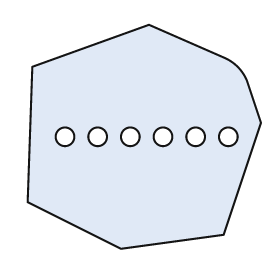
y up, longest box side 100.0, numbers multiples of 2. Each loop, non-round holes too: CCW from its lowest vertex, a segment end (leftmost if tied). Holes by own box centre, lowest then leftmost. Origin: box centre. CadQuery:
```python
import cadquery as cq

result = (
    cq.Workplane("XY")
    .moveTo(-10.0, -48.0)
    .lineTo(34.0, -42.0)
    .lineTo(50.0, 6.0)
    .lineTo(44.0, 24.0)
    .threePointArc((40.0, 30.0), (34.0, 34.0))
    .lineTo(2.0, 48.0)
    .lineTo(-48.0, 30.0)
    .lineTo(-50.0, -28.0)
    .close()
    .moveTo(-34.0, 0.0)
    .circle(4.0)
    .moveTo(-20.0, 0.0)
    .circle(4.0)
    .moveTo(-6.0, 0.0)
    .circle(4.0)
    .moveTo(8.0, 0.0)
    .circle(4.0)
    .moveTo(22.0, 0.0)
    .circle(4.0)
    .moveTo(36.0, 0.0)
    .circle(4.0)
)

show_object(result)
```